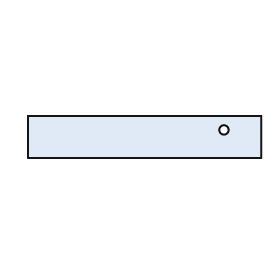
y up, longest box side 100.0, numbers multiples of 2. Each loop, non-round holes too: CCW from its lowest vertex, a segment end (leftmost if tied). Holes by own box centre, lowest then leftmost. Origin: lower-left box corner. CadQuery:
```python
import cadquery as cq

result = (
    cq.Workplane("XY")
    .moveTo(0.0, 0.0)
    .lineTo(100.0, 0.0)
    .lineTo(100.0, 18.0)
    .lineTo(0.0, 18.0)
    .close()
    .moveTo(84.0, 12.0)
    .circle(2.0)
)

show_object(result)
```